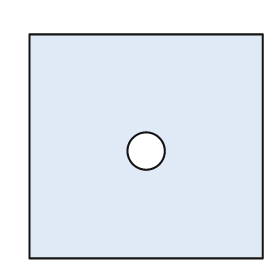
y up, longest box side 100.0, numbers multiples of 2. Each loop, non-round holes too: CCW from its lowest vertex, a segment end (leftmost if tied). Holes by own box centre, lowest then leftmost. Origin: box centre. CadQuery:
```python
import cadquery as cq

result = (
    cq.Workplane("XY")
    .moveTo(-50.0, -48.0)
    .lineTo(50.0, -48.0)
    .lineTo(50.0, 48.0)
    .lineTo(-50.0, 48.0)
    .close()
    .moveTo(0.0, -2.0)
    .circle(8.0)
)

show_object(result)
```